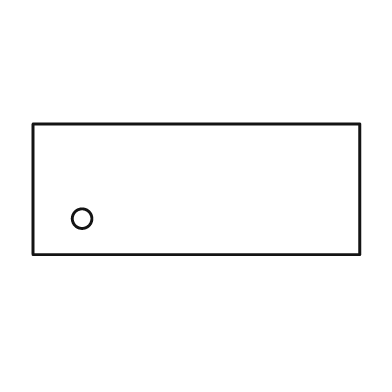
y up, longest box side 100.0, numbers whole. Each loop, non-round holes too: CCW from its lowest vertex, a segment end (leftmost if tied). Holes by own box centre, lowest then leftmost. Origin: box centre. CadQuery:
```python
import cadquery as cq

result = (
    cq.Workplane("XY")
    .moveTo(-50.0, -20.0)
    .lineTo(50.0, -20.0)
    .lineTo(50.0, 20.0)
    .lineTo(-50.0, 20.0)
    .close()
    .moveTo(-35.0, -9.0)
    .circle(3.0)
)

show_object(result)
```